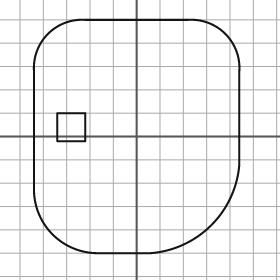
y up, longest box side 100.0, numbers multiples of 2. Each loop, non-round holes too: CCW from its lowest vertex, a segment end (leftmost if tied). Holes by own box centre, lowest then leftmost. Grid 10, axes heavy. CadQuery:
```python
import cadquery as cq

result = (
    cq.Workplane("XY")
    .moveTo(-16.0, -50.0)
    .lineTo(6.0, -50.0)
    .threePointArc((32.0, -38.0), (44.0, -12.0))
    .lineTo(44.0, 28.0)
    .threePointArc((38.0, 44.0), (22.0, 50.0))
    .lineTo(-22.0, 50.0)
    .threePointArc((-38.0, 44.0), (-44.0, 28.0))
    .lineTo(-44.0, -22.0)
    .threePointArc((-36.0, -42.0), (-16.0, -50.0))
    .close()
    .moveTo(-34.0, -2.0)
    .lineTo(-22.0, -2.0)
    .lineTo(-22.0, 10.0)
    .lineTo(-34.0, 10.0)
    .close()
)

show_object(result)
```